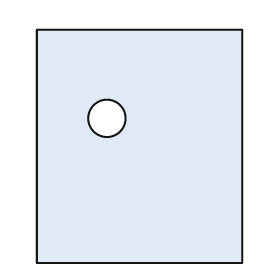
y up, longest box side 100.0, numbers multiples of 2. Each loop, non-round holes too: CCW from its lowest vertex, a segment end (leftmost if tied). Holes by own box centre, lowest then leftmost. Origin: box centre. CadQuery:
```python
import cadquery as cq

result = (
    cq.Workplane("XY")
    .moveTo(-44.0, -50.0)
    .lineTo(44.0, -50.0)
    .lineTo(44.0, 50.0)
    .lineTo(-44.0, 50.0)
    .close()
    .moveTo(-14.0, 12.0)
    .circle(8.0)
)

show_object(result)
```